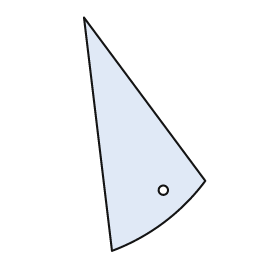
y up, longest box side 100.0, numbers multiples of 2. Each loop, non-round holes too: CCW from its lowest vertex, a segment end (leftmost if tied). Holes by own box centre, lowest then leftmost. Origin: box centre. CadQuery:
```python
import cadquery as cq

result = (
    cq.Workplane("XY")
    .moveTo(-14.0, -50.0)
    .threePointArc((8.0, -38.0), (26.0, -20.0))
    .lineTo(-26.0, 50.0)
    .close()
    .moveTo(8.0, -24.0)
    .circle(2.0)
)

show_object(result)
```